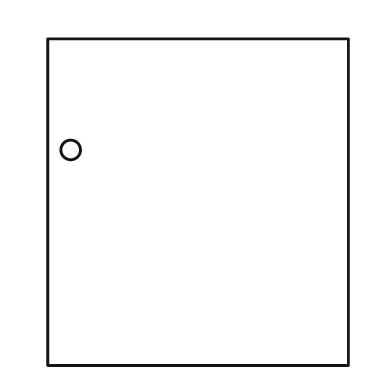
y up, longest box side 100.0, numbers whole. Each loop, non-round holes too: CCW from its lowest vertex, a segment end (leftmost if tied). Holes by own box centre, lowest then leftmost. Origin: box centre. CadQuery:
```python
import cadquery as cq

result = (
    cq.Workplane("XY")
    .moveTo(-46.0, -50.0)
    .lineTo(46.0, -50.0)
    .lineTo(46.0, 50.0)
    .lineTo(-46.0, 50.0)
    .close()
    .moveTo(-39.0, 16.0)
    .circle(3.0)
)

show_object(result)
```